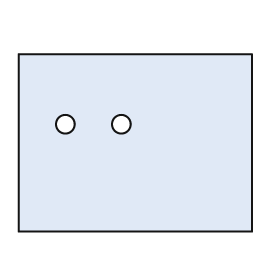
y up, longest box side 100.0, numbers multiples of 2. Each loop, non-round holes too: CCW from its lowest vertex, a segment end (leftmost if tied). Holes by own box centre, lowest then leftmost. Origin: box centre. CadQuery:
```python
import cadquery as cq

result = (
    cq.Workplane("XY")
    .moveTo(-50.0, -38.0)
    .lineTo(50.0, -38.0)
    .lineTo(50.0, 38.0)
    .lineTo(-50.0, 38.0)
    .close()
    .moveTo(-30.0, 8.0)
    .circle(4.0)
    .moveTo(-6.0, 8.0)
    .circle(4.0)
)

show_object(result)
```